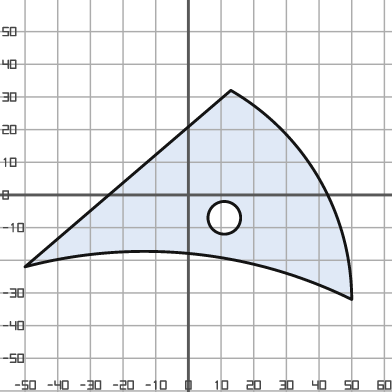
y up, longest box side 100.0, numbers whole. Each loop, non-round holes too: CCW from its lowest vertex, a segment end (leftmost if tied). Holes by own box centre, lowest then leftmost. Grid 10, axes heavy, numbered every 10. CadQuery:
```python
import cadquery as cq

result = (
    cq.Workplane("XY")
    .moveTo(50.0, -32.0)
    .threePointArc((40.0, 5.0), (13.0, 32.0))
    .lineTo(-50.0, -22.0)
    .threePointArc((1.0, -18.0), (50.0, -32.0))
    .close()
    .moveTo(11.0, -7.0)
    .circle(5.0)
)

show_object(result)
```